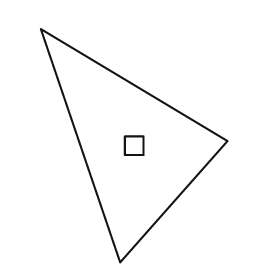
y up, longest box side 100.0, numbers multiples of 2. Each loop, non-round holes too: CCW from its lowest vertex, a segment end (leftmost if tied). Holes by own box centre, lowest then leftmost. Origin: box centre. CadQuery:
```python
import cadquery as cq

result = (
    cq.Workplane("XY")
    .moveTo(-6.0, -50.0)
    .lineTo(40.0, 2.0)
    .lineTo(-40.0, 50.0)
    .close()
    .moveTo(-4.0, -4.0)
    .lineTo(4.0, -4.0)
    .lineTo(4.0, 4.0)
    .lineTo(-4.0, 4.0)
    .close()
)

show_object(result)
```